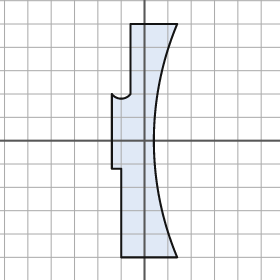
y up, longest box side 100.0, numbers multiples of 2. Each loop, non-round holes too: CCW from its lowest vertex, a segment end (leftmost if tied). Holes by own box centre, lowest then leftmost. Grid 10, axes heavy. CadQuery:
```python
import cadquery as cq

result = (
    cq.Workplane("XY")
    .moveTo(-10.0, -50.0)
    .lineTo(14.0, -50.0)
    .threePointArc((4.0, 0.0), (14.0, 50.0))
    .lineTo(-6.0, 50.0)
    .lineTo(-6.0, 20.0)
    .threePointArc((-10.0, 18.0), (-14.0, 20.0))
    .lineTo(-14.0, -12.0)
    .lineTo(-10.0, -12.0)
    .close()
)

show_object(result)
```